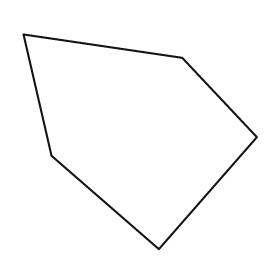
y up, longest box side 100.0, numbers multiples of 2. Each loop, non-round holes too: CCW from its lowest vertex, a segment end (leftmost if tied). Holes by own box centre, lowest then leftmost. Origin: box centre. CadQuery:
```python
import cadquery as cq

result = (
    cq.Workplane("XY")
    .moveTo(8.0, -46.0)
    .lineTo(50.0, 2.0)
    .lineTo(18.0, 36.0)
    .lineTo(-50.0, 46.0)
    .lineTo(-38.0, -6.0)
    .close()
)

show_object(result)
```